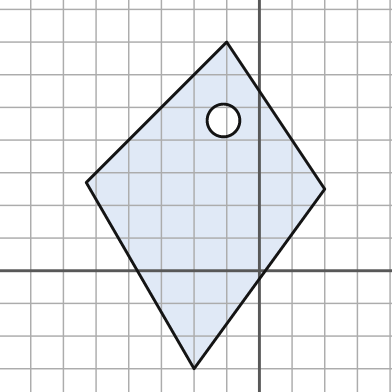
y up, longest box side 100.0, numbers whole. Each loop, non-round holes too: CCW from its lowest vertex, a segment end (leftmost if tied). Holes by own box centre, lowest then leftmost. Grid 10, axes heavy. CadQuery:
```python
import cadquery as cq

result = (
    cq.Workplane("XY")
    .moveTo(-20.0, -30.0)
    .lineTo(20.0, 25.0)
    .lineTo(-10.0, 70.0)
    .lineTo(-53.0, 27.0)
    .close()
    .moveTo(-11.0, 46.0)
    .circle(5.0)
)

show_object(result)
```